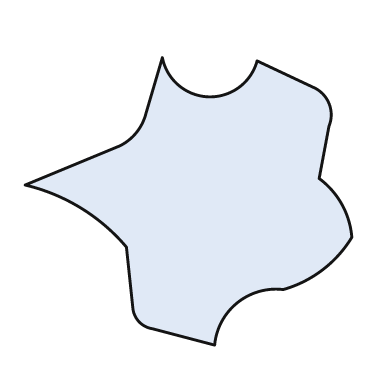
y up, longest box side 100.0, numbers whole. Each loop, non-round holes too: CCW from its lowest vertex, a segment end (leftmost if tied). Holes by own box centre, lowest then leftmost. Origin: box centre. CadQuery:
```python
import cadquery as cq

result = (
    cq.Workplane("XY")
    .moveTo(8.0, -44.0)
    .threePointArc((15.0, -31.0), (29.0, -27.0))
    .threePointArc((41.0, -21.0), (50.0, -11.0))
    .threePointArc((47.0, -1.0), (40.0, 7.0))
    .lineTo(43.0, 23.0)
    .threePointArc((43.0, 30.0), (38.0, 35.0))
    .lineTo(21.0, 43.0)
    .threePointArc((6.0, 32.0), (-8.0, 44.0))
    .lineTo(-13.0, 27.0)
    .threePointArc((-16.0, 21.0), (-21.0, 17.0))
    .lineTo(-50.0, 5.0)
    .threePointArc((-33.0, -2.0), (-19.0, -14.0))
    .lineTo(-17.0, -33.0)
    .threePointArc((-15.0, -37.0), (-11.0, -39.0))
    .close()
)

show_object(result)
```